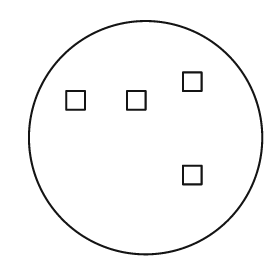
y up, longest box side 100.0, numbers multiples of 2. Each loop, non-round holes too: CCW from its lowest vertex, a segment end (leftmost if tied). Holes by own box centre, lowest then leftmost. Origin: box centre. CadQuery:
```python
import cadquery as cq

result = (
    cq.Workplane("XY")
    .moveTo(0.0, 0.0)
    .circle(50.0)
    .moveTo(16.0, -20.0)
    .lineTo(24.0, -20.0)
    .lineTo(24.0, -12.0)
    .lineTo(16.0, -12.0)
    .close()
    .moveTo(-34.0, 12.0)
    .lineTo(-26.0, 12.0)
    .lineTo(-26.0, 20.0)
    .lineTo(-34.0, 20.0)
    .close()
    .moveTo(-8.0, 12.0)
    .lineTo(0.0, 12.0)
    .lineTo(0.0, 20.0)
    .lineTo(-8.0, 20.0)
    .close()
    .moveTo(16.0, 20.0)
    .lineTo(24.0, 20.0)
    .lineTo(24.0, 28.0)
    .lineTo(16.0, 28.0)
    .close()
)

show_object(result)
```